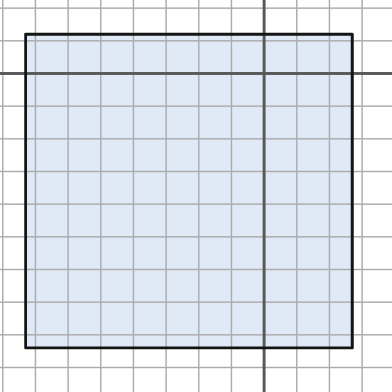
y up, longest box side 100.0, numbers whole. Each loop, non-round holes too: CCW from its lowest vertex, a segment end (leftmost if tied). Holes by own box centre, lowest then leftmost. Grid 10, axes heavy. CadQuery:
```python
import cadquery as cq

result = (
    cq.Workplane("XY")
    .moveTo(-73.0, -84.0)
    .lineTo(27.0, -84.0)
    .lineTo(27.0, 12.0)
    .lineTo(-73.0, 12.0)
    .close()
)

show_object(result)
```